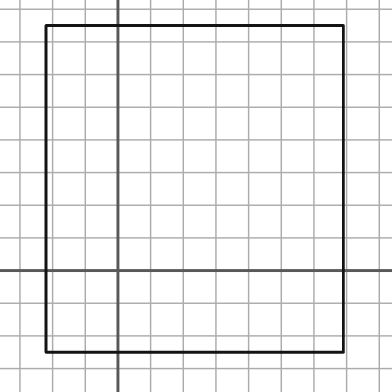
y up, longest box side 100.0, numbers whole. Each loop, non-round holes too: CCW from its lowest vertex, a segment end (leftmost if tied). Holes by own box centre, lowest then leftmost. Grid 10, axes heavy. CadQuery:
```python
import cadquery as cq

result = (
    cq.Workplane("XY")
    .moveTo(-22.0, -25.0)
    .lineTo(69.0, -25.0)
    .lineTo(69.0, 75.0)
    .lineTo(-22.0, 75.0)
    .close()
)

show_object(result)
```